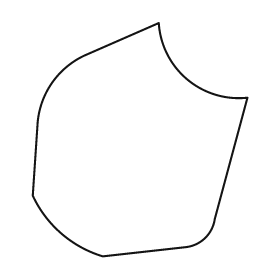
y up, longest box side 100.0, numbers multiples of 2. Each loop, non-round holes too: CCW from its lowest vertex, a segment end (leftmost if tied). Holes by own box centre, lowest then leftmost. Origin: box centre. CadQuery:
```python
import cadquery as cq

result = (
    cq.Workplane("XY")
    .moveTo(-16.0, -50.0)
    .lineTo(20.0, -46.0)
    .threePointArc((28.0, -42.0), (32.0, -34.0))
    .lineTo(46.0, 18.0)
    .threePointArc((20.0, 26.0), (8.0, 50.0))
    .lineTo(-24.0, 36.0)
    .threePointArc((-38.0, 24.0), (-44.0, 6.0))
    .lineTo(-46.0, -24.0)
    .threePointArc((-34.0, -40.0), (-16.0, -50.0))
    .close()
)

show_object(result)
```